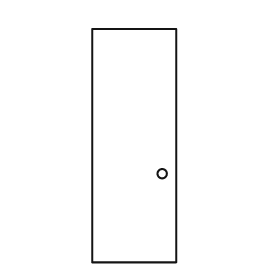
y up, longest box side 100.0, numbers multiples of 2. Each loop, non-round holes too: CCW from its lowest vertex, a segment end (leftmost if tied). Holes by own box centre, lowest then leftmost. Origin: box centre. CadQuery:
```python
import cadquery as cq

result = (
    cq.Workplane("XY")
    .moveTo(-18.0, -50.0)
    .lineTo(18.0, -50.0)
    .lineTo(18.0, 50.0)
    .lineTo(-18.0, 50.0)
    .close()
    .moveTo(12.0, -12.0)
    .circle(2.0)
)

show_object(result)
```